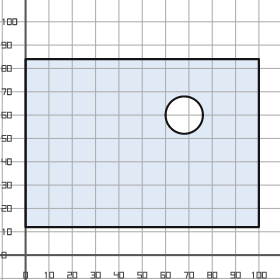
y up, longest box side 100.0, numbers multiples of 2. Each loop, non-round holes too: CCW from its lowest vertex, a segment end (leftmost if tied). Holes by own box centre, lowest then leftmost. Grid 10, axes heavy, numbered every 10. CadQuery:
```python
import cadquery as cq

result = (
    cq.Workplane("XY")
    .moveTo(0.0, 12.0)
    .lineTo(100.0, 12.0)
    .lineTo(100.0, 84.0)
    .lineTo(0.0, 84.0)
    .close()
    .moveTo(68.0, 60.0)
    .circle(8.0)
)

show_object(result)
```